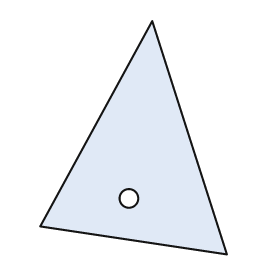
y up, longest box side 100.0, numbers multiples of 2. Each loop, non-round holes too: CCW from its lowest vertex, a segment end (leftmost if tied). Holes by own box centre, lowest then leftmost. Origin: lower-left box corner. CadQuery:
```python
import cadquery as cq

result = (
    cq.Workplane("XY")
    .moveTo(80.0, 0.0)
    .lineTo(48.0, 100.0)
    .lineTo(0.0, 12.0)
    .close()
    .moveTo(38.0, 24.0)
    .circle(4.0)
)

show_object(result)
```